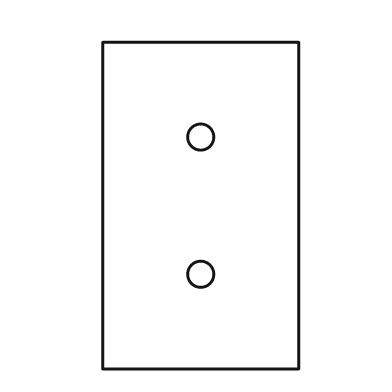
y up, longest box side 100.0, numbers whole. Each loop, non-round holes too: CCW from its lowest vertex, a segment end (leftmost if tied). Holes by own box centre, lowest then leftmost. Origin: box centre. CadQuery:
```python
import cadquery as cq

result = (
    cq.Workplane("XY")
    .moveTo(-30.0, -50.0)
    .lineTo(30.0, -50.0)
    .lineTo(30.0, 50.0)
    .lineTo(-30.0, 50.0)
    .close()
    .moveTo(0.0, -21.0)
    .circle(4.0)
    .moveTo(0.0, 21.0)
    .circle(4.0)
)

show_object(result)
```